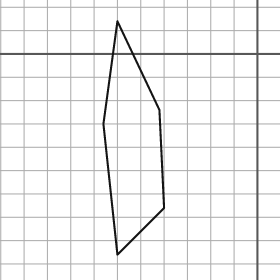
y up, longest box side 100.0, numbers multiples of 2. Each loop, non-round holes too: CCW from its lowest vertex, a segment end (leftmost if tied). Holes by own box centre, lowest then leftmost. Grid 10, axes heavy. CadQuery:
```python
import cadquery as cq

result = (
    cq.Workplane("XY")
    .moveTo(-60.0, -86.0)
    .lineTo(-40.0, -66.0)
    .lineTo(-42.0, -24.0)
    .lineTo(-60.0, 14.0)
    .lineTo(-66.0, -30.0)
    .close()
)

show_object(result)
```